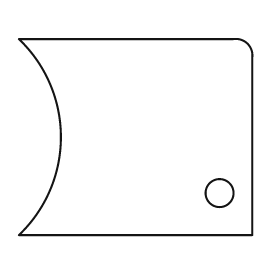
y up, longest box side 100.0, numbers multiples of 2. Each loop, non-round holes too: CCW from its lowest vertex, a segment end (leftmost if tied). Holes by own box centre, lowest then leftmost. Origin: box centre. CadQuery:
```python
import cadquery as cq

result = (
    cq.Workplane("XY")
    .moveTo(-50.0, -42.0)
    .lineTo(50.0, -42.0)
    .lineTo(50.0, 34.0)
    .threePointArc((48.0, 40.0), (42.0, 42.0))
    .lineTo(-50.0, 42.0)
    .threePointArc((-32.0, 0.0), (-50.0, -42.0))
    .close()
    .moveTo(36.0, -24.0)
    .circle(6.0)
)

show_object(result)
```